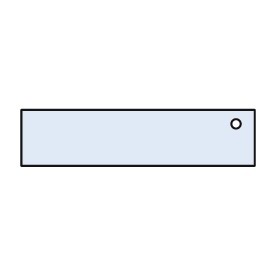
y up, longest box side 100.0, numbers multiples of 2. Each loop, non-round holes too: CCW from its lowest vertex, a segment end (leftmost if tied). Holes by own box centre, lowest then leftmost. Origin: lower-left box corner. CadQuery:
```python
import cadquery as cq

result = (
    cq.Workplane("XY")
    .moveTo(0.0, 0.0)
    .lineTo(100.0, 0.0)
    .lineTo(100.0, 24.0)
    .lineTo(0.0, 24.0)
    .close()
    .moveTo(92.0, 18.0)
    .circle(2.0)
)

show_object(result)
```